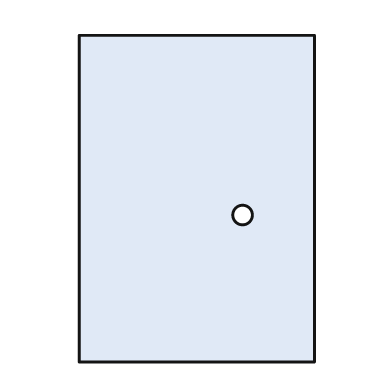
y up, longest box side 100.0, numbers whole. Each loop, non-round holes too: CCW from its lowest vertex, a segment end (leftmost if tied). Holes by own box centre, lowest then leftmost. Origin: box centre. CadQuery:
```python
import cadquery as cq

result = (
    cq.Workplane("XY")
    .moveTo(-36.0, -50.0)
    .lineTo(36.0, -50.0)
    .lineTo(36.0, 50.0)
    .lineTo(-36.0, 50.0)
    .close()
    .moveTo(14.0, -5.0)
    .circle(3.0)
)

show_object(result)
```